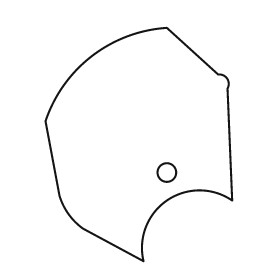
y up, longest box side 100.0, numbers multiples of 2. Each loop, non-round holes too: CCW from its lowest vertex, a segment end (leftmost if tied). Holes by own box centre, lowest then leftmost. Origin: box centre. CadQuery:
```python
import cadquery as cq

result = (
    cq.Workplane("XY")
    .moveTo(2.0, -50.0)
    .threePointArc((12.0, -24.0), (40.0, -24.0))
    .lineTo(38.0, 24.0)
    .threePointArc((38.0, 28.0), (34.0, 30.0))
    .lineTo(12.0, 50.0)
    .threePointArc((-20.0, 38.0), (-40.0, 10.0))
    .lineTo(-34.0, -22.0)
    .threePointArc((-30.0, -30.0), (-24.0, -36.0))
    .close()
    .moveTo(12.0, -12.0)
    .circle(4.0)
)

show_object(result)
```